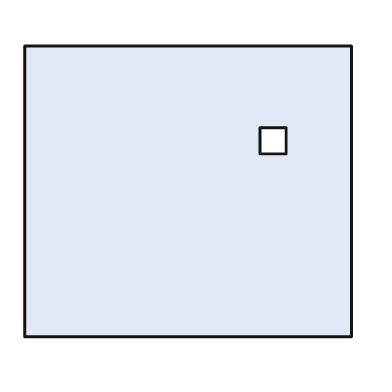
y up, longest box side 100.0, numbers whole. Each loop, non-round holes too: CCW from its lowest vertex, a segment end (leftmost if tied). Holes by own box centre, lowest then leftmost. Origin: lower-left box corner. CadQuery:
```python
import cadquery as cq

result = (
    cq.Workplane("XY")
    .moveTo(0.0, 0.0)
    .lineTo(100.0, 0.0)
    .lineTo(100.0, 89.0)
    .lineTo(0.0, 89.0)
    .close()
    .moveTo(72.0, 56.0)
    .lineTo(80.0, 56.0)
    .lineTo(80.0, 64.0)
    .lineTo(72.0, 64.0)
    .close()
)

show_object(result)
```